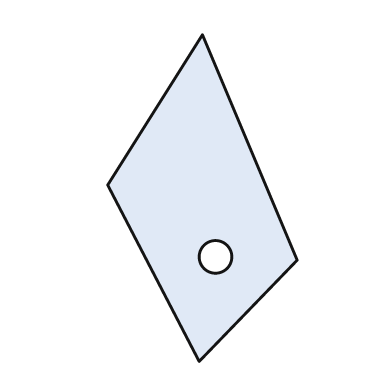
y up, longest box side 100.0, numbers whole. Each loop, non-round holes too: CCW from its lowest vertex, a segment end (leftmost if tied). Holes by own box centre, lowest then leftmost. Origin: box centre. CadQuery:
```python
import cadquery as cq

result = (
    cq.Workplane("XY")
    .moveTo(-1.0, -50.0)
    .lineTo(29.0, -19.0)
    .lineTo(0.0, 50.0)
    .lineTo(-29.0, 4.0)
    .close()
    .moveTo(4.0, -18.0)
    .circle(5.0)
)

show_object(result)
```